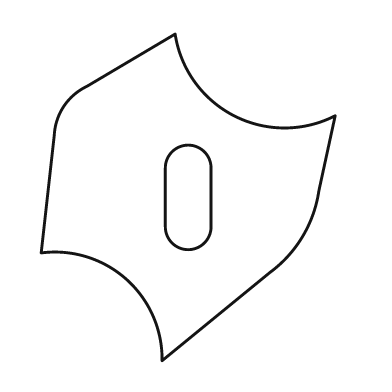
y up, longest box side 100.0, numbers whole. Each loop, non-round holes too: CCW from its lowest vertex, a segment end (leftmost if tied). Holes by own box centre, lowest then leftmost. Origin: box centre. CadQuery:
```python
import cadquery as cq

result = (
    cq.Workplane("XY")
    .moveTo(-8.0, -50.0)
    .lineTo(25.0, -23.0)
    .threePointArc((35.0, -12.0), (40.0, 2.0))
    .lineTo(45.0, 25.0)
    .threePointArc((14.0, 25.0), (-4.0, 50.0))
    .lineTo(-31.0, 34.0)
    .threePointArc((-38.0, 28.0), (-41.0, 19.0))
    .lineTo(-45.0, -17.0)
    .threePointArc((-19.0, -25.0), (-8.0, -50.0))
    .close()
    .moveTo(-7.0, -9.0)
    .threePointArc((0.0, -16.0), (7.0, -9.0))
    .lineTo(7.0, 9.0)
    .threePointArc((0.0, 16.0), (-7.0, 9.0))
    .close()
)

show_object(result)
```